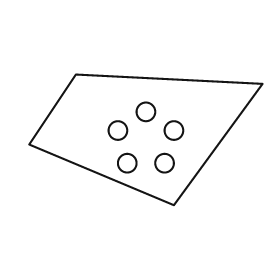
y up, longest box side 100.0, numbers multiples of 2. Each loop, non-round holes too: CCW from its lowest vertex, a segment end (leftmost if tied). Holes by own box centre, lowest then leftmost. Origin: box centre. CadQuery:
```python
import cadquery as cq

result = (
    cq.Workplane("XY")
    .moveTo(12.0, -28.0)
    .lineTo(50.0, 24.0)
    .lineTo(-30.0, 28.0)
    .lineTo(-50.0, -2.0)
    .close()
    .moveTo(-8.0, -10.0)
    .circle(4.0)
    .moveTo(8.0, -10.0)
    .circle(4.0)
    .moveTo(-12.0, 4.0)
    .circle(4.0)
    .moveTo(12.0, 4.0)
    .circle(4.0)
    .moveTo(0.0, 12.0)
    .circle(4.0)
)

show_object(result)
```